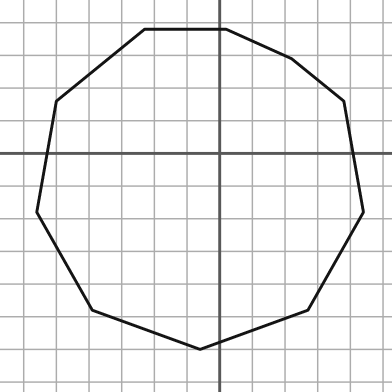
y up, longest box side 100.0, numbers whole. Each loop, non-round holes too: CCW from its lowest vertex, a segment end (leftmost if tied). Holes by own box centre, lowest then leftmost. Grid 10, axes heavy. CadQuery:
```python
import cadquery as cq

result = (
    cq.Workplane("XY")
    .moveTo(-6.0, -60.0)
    .lineTo(27.0, -48.0)
    .lineTo(44.0, -18.0)
    .lineTo(38.0, 16.0)
    .lineTo(22.0, 29.0)
    .lineTo(2.0, 38.0)
    .lineTo(-23.0, 38.0)
    .lineTo(-50.0, 16.0)
    .lineTo(-56.0, -18.0)
    .lineTo(-39.0, -48.0)
    .close()
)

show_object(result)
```